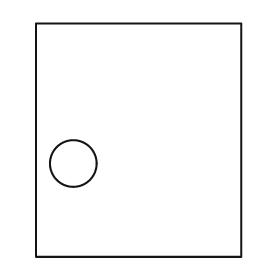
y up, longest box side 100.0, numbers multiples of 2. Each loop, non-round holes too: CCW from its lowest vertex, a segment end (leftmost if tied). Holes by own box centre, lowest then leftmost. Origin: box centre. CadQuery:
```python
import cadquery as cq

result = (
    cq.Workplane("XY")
    .moveTo(-44.0, -50.0)
    .lineTo(44.0, -50.0)
    .lineTo(44.0, 50.0)
    .lineTo(-44.0, 50.0)
    .close()
    .moveTo(-28.0, -10.0)
    .circle(10.0)
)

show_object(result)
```